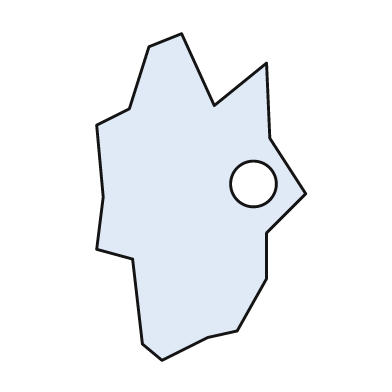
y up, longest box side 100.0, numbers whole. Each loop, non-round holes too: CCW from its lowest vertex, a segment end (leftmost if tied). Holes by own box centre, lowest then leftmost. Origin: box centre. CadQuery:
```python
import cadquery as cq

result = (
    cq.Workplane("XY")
    .moveTo(-12.0, -50.0)
    .lineTo(2.0, -43.0)
    .lineTo(11.0, -41.0)
    .lineTo(20.0, -25.0)
    .lineTo(20.0, -11.0)
    .lineTo(32.0, 1.0)
    .lineTo(21.0, 18.0)
    .lineTo(20.0, 41.0)
    .lineTo(4.0, 28.0)
    .lineTo(-6.0, 50.0)
    .lineTo(-16.0, 46.0)
    .lineTo(-22.0, 27.0)
    .lineTo(-32.0, 22.0)
    .lineTo(-30.0, 0.0)
    .lineTo(-32.0, -16.0)
    .lineTo(-21.0, -19.0)
    .lineTo(-18.0, -45.0)
    .close()
    .moveTo(16.0, 4.0)
    .circle(7.0)
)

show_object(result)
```